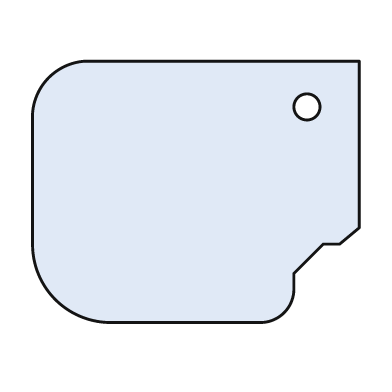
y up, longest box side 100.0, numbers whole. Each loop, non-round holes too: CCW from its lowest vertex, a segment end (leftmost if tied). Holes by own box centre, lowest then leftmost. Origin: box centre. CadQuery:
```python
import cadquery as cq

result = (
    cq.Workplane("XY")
    .moveTo(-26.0, -40.0)
    .lineTo(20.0, -40.0)
    .threePointArc((27.0, -37.0), (30.0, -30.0))
    .lineTo(30.0, -25.0)
    .lineTo(39.0, -16.0)
    .lineTo(44.0, -16.0)
    .lineTo(50.0, -11.0)
    .lineTo(50.0, 40.0)
    .lineTo(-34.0, 40.0)
    .threePointArc((-45.0, 35.0), (-50.0, 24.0))
    .lineTo(-50.0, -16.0)
    .threePointArc((-43.0, -33.0), (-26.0, -40.0))
    .close()
    .moveTo(34.0, 26.0)
    .circle(4.0)
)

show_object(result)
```